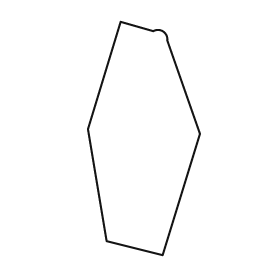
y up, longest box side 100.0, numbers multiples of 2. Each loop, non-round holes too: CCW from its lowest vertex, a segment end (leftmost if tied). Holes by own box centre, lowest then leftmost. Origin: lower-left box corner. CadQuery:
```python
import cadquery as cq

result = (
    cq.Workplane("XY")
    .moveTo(32.0, 0.0)
    .lineTo(48.0, 52.0)
    .lineTo(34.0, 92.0)
    .threePointArc((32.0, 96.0), (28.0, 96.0))
    .lineTo(14.0, 100.0)
    .lineTo(0.0, 54.0)
    .lineTo(8.0, 6.0)
    .close()
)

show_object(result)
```